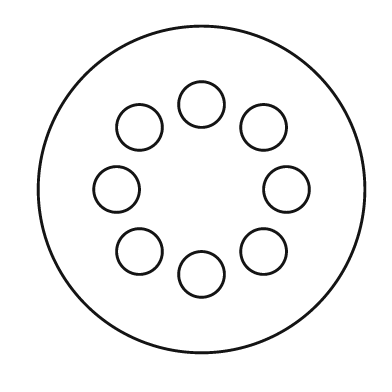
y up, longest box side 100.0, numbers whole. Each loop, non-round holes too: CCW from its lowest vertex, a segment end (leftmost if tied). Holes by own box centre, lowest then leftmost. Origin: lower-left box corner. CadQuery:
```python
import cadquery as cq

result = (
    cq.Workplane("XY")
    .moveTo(50.0, 50.0)
    .circle(50.0)
    .moveTo(50.0, 24.0)
    .circle(7.0)
    .moveTo(31.0, 31.0)
    .circle(7.0)
    .moveTo(69.0, 31.0)
    .circle(7.0)
    .moveTo(24.0, 50.0)
    .circle(7.0)
    .moveTo(76.0, 50.0)
    .circle(7.0)
    .moveTo(31.0, 69.0)
    .circle(7.0)
    .moveTo(69.0, 69.0)
    .circle(7.0)
    .moveTo(50.0, 76.0)
    .circle(7.0)
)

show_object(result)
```